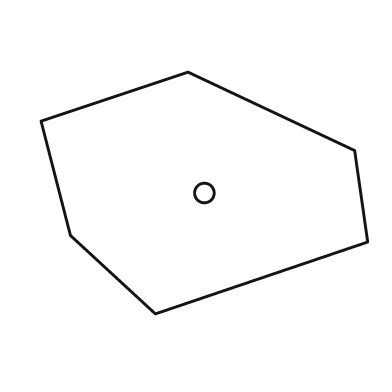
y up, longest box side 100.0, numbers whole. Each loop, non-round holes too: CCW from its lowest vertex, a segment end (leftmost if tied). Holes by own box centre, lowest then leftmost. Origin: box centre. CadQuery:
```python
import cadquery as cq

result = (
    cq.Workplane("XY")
    .moveTo(-15.0, -37.0)
    .lineTo(50.0, -15.0)
    .lineTo(46.0, 13.0)
    .lineTo(-5.0, 37.0)
    .lineTo(-50.0, 22.0)
    .lineTo(-41.0, -13.0)
    .close()
    .moveTo(0.0, 0.0)
    .circle(3.0)
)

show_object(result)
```